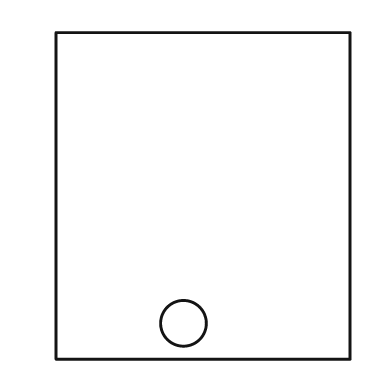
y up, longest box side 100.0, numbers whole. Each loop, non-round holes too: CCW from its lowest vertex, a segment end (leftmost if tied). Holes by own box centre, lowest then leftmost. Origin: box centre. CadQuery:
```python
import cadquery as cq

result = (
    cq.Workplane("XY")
    .moveTo(-45.0, -50.0)
    .lineTo(45.0, -50.0)
    .lineTo(45.0, 50.0)
    .lineTo(-45.0, 50.0)
    .close()
    .moveTo(-6.0, -39.0)
    .circle(7.0)
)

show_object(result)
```